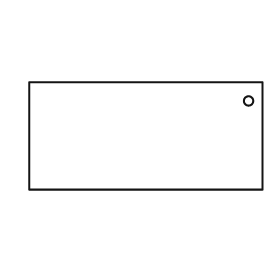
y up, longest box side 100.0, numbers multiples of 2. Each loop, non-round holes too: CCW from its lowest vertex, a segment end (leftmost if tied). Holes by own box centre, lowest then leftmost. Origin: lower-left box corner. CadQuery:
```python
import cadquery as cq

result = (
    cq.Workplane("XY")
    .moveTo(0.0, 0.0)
    .lineTo(100.0, 0.0)
    .lineTo(100.0, 46.0)
    .lineTo(0.0, 46.0)
    .close()
    .moveTo(94.0, 38.0)
    .circle(2.0)
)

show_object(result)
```